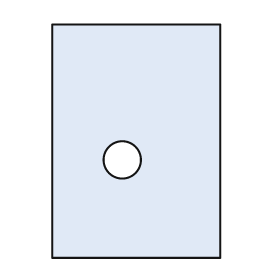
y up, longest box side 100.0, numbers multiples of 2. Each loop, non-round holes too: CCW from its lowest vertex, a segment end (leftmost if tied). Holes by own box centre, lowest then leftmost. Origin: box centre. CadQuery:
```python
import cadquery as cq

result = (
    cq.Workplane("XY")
    .moveTo(-36.0, -50.0)
    .lineTo(36.0, -50.0)
    .lineTo(36.0, 50.0)
    .lineTo(-36.0, 50.0)
    .close()
    .moveTo(-6.0, -8.0)
    .circle(8.0)
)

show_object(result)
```